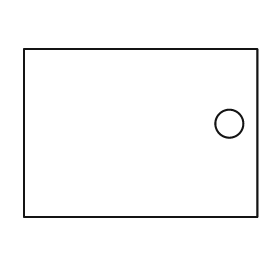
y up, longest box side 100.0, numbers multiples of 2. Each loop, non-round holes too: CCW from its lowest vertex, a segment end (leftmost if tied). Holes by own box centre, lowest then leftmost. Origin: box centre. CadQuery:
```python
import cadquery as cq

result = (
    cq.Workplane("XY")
    .moveTo(-50.0, -36.0)
    .lineTo(50.0, -36.0)
    .lineTo(50.0, 36.0)
    .lineTo(-50.0, 36.0)
    .close()
    .moveTo(38.0, 4.0)
    .circle(6.0)
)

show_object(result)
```